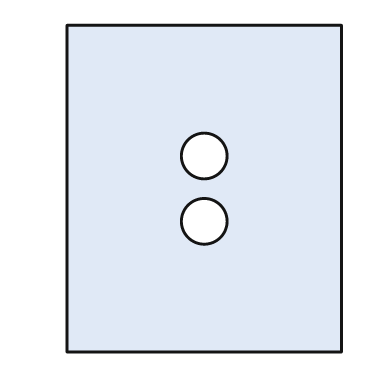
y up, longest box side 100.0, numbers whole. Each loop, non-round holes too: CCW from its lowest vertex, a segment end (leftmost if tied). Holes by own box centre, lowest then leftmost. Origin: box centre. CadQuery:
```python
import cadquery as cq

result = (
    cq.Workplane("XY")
    .moveTo(-42.0, -50.0)
    .lineTo(42.0, -50.0)
    .lineTo(42.0, 50.0)
    .lineTo(-42.0, 50.0)
    .close()
    .moveTo(0.0, -10.0)
    .circle(7.0)
    .moveTo(0.0, 10.0)
    .circle(7.0)
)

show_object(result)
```